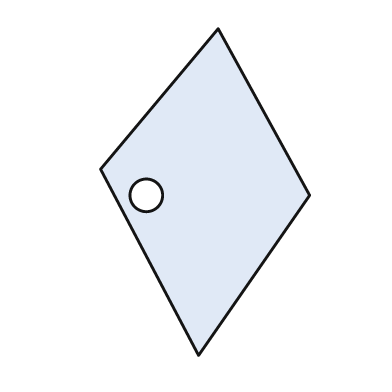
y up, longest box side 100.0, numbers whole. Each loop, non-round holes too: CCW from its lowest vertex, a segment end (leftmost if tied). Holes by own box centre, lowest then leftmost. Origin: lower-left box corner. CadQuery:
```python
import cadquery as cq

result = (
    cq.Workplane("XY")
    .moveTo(30.0, 0.0)
    .lineTo(64.0, 49.0)
    .lineTo(36.0, 100.0)
    .lineTo(0.0, 57.0)
    .close()
    .moveTo(14.0, 49.0)
    .circle(5.0)
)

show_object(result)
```